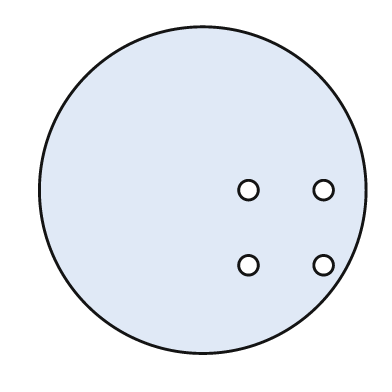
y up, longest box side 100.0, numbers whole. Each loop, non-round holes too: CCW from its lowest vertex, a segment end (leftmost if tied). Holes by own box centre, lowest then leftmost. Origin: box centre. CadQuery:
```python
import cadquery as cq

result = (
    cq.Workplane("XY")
    .moveTo(0.0, 0.0)
    .circle(50.0)
    .moveTo(14.0, -23.0)
    .circle(3.0)
    .moveTo(37.0, -23.0)
    .circle(3.0)
    .moveTo(14.0, 0.0)
    .circle(3.0)
    .moveTo(37.0, 0.0)
    .circle(3.0)
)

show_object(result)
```